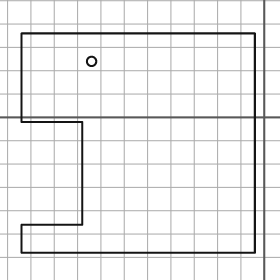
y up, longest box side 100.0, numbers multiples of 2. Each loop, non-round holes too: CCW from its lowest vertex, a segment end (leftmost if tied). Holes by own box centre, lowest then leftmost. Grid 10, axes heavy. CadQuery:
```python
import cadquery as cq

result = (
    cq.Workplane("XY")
    .moveTo(-104.0, -58.0)
    .lineTo(-4.0, -58.0)
    .lineTo(-4.0, 36.0)
    .lineTo(-104.0, 36.0)
    .lineTo(-104.0, -2.0)
    .lineTo(-78.0, -2.0)
    .lineTo(-78.0, -46.0)
    .lineTo(-104.0, -46.0)
    .close()
    .moveTo(-74.0, 24.0)
    .circle(2.0)
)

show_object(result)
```